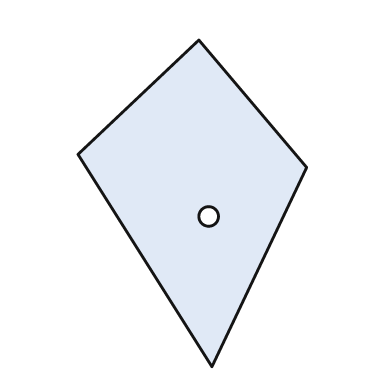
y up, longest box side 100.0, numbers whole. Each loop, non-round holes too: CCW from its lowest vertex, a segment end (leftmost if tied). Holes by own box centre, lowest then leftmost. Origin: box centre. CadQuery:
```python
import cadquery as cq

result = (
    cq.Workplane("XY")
    .moveTo(6.0, -50.0)
    .lineTo(35.0, 11.0)
    .lineTo(2.0, 50.0)
    .lineTo(-35.0, 15.0)
    .close()
    .moveTo(5.0, -4.0)
    .circle(3.0)
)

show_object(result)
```